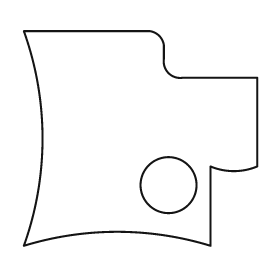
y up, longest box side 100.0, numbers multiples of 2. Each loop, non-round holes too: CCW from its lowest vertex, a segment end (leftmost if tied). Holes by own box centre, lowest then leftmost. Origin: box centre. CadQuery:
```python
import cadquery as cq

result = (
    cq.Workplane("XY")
    .moveTo(-50.0, -46.0)
    .threePointArc((-10.0, -40.0), (30.0, -46.0))
    .lineTo(30.0, -12.0)
    .threePointArc((40.0, -14.0), (50.0, -12.0))
    .lineTo(50.0, 26.0)
    .lineTo(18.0, 26.0)
    .threePointArc((12.0, 28.0), (10.0, 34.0))
    .lineTo(10.0, 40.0)
    .threePointArc((8.0, 44.0), (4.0, 46.0))
    .lineTo(-50.0, 46.0)
    .threePointArc((-42.0, 0.0), (-50.0, -46.0))
    .close()
    .moveTo(12.0, -20.0)
    .circle(12.0)
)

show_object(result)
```